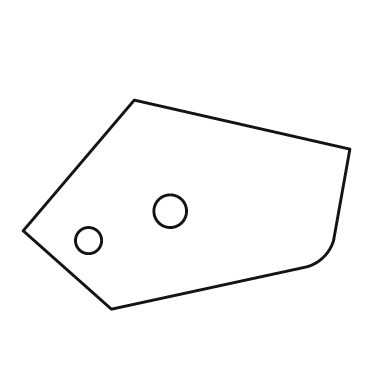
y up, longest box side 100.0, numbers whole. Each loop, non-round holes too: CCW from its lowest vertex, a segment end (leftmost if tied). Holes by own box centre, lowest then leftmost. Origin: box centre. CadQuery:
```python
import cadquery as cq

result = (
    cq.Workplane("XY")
    .moveTo(-23.0, -32.0)
    .lineTo(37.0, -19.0)
    .threePointArc((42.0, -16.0), (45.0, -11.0))
    .lineTo(50.0, 17.0)
    .lineTo(-16.0, 32.0)
    .lineTo(-50.0, -8.0)
    .close()
    .moveTo(-30.0, -11.0)
    .circle(4.0)
    .moveTo(-5.0, -2.0)
    .circle(5.0)
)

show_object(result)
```